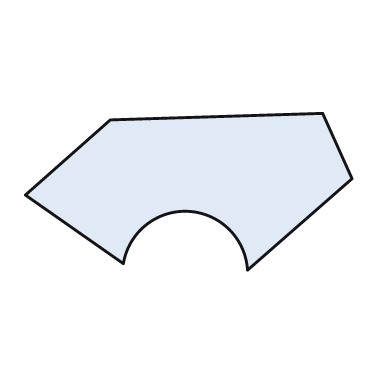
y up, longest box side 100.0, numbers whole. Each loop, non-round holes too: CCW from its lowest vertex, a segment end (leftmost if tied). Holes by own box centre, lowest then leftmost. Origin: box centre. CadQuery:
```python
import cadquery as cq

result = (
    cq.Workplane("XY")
    .moveTo(18.0, -24.0)
    .lineTo(50.0, 4.0)
    .lineTo(41.0, 24.0)
    .lineTo(-24.0, 22.0)
    .lineTo(-50.0, -1.0)
    .lineTo(-20.0, -22.0)
    .threePointArc((0.0, -6.0), (18.0, -24.0))
    .close()
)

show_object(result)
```